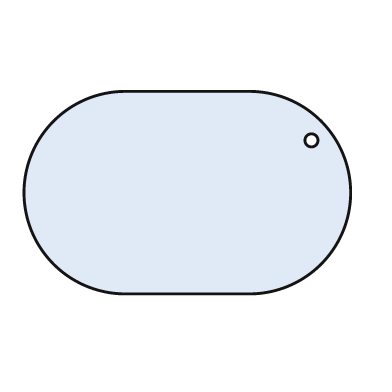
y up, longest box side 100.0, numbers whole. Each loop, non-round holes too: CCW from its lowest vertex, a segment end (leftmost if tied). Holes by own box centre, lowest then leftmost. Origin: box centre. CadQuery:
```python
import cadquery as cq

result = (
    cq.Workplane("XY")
    .moveTo(-19.0, -31.0)
    .lineTo(19.0, -31.0)
    .threePointArc((50.0, 0.0), (19.0, 31.0))
    .lineTo(-19.0, 31.0)
    .threePointArc((-50.0, 0.0), (-19.0, -31.0))
    .close()
    .moveTo(38.0, 16.0)
    .circle(2.0)
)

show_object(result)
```